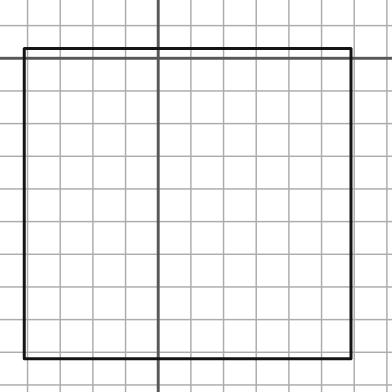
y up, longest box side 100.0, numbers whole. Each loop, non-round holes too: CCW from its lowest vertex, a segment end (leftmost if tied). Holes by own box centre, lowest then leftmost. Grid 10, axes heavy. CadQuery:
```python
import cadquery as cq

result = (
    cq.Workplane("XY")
    .moveTo(-41.0, -92.0)
    .lineTo(59.0, -92.0)
    .lineTo(59.0, 3.0)
    .lineTo(-41.0, 3.0)
    .close()
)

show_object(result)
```